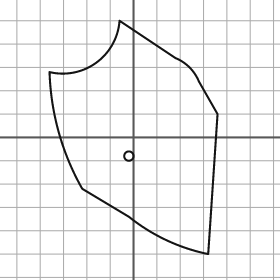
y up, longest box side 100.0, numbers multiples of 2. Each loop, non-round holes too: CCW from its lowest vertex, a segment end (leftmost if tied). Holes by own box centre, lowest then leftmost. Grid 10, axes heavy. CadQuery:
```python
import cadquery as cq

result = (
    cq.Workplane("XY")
    .moveTo(32.0, -50.0)
    .lineTo(36.0, 10.0)
    .lineTo(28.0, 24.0)
    .threePointArc((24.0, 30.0), (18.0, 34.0))
    .lineTo(-6.0, 50.0)
    .threePointArc((-16.0, 32.0), (-36.0, 28.0))
    .threePointArc((-32.0, 2.0), (-22.0, -22.0))
    .lineTo(-2.0, -34.0)
    .threePointArc((14.0, -44.0), (32.0, -50.0))
    .close()
    .moveTo(-2.0, -8.0)
    .circle(2.0)
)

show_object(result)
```